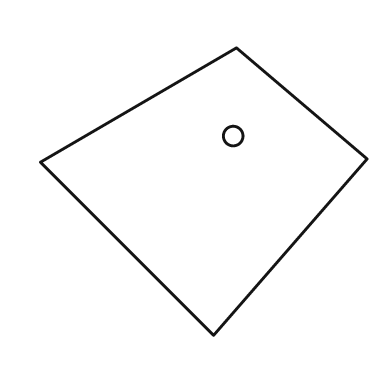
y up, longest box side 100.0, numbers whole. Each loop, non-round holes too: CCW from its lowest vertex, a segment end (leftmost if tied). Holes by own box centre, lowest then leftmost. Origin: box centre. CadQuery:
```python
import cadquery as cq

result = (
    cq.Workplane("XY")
    .moveTo(3.0, -44.0)
    .lineTo(50.0, 10.0)
    .lineTo(10.0, 44.0)
    .lineTo(-50.0, 9.0)
    .close()
    .moveTo(9.0, 17.0)
    .circle(3.0)
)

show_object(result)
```